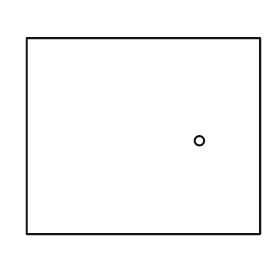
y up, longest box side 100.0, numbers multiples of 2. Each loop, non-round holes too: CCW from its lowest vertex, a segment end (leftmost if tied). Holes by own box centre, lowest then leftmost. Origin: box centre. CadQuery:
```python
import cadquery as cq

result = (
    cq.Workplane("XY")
    .moveTo(-50.0, -42.0)
    .lineTo(50.0, -42.0)
    .lineTo(50.0, 42.0)
    .lineTo(-50.0, 42.0)
    .close()
    .moveTo(24.0, -2.0)
    .circle(2.0)
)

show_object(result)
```